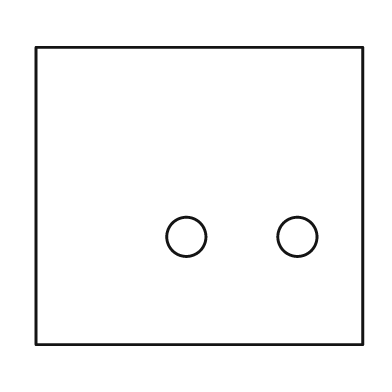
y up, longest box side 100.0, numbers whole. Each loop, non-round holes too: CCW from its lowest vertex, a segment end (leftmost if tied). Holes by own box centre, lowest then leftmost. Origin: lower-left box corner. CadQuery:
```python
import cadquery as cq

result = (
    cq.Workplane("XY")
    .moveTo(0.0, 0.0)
    .lineTo(100.0, 0.0)
    .lineTo(100.0, 91.0)
    .lineTo(0.0, 91.0)
    .close()
    .moveTo(46.0, 33.0)
    .circle(6.0)
    .moveTo(80.0, 33.0)
    .circle(6.0)
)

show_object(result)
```